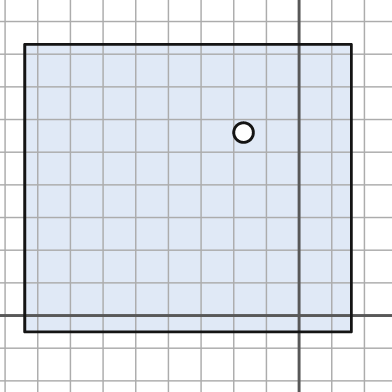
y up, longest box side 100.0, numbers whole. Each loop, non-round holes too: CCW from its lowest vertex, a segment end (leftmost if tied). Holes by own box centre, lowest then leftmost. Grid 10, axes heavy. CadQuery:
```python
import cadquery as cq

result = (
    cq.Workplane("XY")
    .moveTo(-84.0, -5.0)
    .lineTo(16.0, -5.0)
    .lineTo(16.0, 83.0)
    .lineTo(-84.0, 83.0)
    .close()
    .moveTo(-17.0, 56.0)
    .circle(3.0)
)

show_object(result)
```